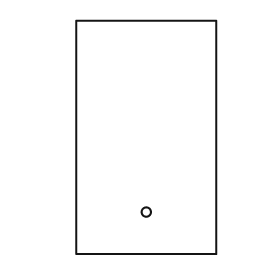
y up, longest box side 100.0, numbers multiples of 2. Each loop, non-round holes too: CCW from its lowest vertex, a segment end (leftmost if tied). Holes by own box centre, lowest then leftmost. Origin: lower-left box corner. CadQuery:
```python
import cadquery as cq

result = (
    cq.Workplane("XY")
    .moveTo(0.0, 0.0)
    .lineTo(60.0, 0.0)
    .lineTo(60.0, 100.0)
    .lineTo(0.0, 100.0)
    .close()
    .moveTo(30.0, 18.0)
    .circle(2.0)
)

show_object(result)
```